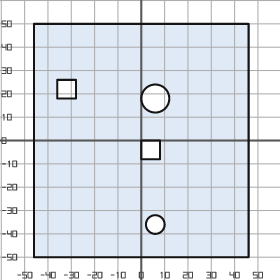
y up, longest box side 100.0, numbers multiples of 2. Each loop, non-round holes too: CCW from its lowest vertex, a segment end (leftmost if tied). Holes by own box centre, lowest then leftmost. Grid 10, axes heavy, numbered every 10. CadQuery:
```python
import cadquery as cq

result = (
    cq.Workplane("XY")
    .moveTo(-46.0, -50.0)
    .lineTo(46.0, -50.0)
    .lineTo(46.0, 50.0)
    .lineTo(-46.0, 50.0)
    .close()
    .moveTo(6.0, -36.0)
    .circle(4.0)
    .moveTo(0.0, -8.0)
    .lineTo(8.0, -8.0)
    .lineTo(8.0, 0.0)
    .lineTo(0.0, 0.0)
    .close()
    .moveTo(6.0, 18.0)
    .circle(6.0)
    .moveTo(-36.0, 18.0)
    .lineTo(-28.0, 18.0)
    .lineTo(-28.0, 26.0)
    .lineTo(-36.0, 26.0)
    .close()
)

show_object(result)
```